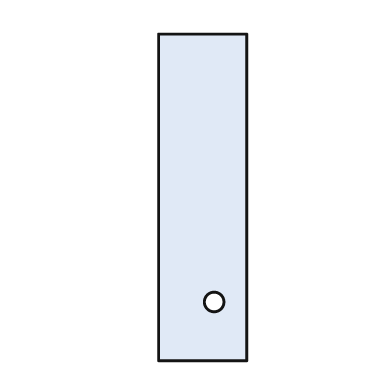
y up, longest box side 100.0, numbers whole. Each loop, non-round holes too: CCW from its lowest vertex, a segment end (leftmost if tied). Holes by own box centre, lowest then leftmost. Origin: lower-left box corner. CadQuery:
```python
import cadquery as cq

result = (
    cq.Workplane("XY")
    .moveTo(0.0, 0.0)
    .lineTo(27.0, 0.0)
    .lineTo(27.0, 100.0)
    .lineTo(0.0, 100.0)
    .close()
    .moveTo(17.0, 18.0)
    .circle(3.0)
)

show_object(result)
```